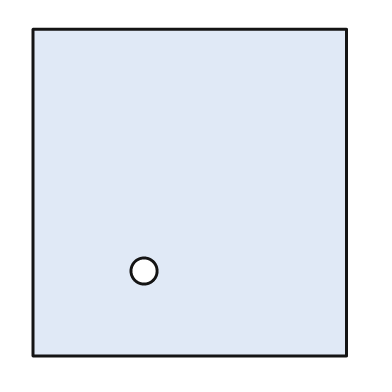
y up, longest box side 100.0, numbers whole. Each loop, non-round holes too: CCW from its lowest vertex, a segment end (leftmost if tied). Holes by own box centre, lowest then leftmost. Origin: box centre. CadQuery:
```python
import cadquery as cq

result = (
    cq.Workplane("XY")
    .moveTo(-48.0, -50.0)
    .lineTo(48.0, -50.0)
    .lineTo(48.0, 50.0)
    .lineTo(-48.0, 50.0)
    .close()
    .moveTo(-14.0, -24.0)
    .circle(4.0)
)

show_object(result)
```